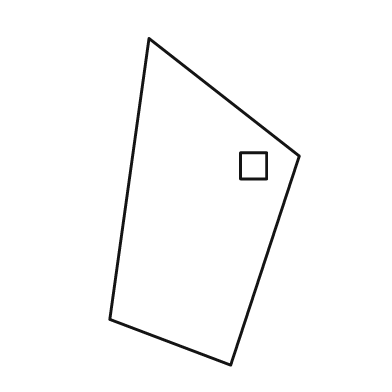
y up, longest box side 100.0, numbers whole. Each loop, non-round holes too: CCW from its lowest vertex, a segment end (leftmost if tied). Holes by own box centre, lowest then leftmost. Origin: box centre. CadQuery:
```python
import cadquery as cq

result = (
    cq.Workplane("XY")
    .moveTo(8.0, -50.0)
    .lineTo(29.0, 14.0)
    .lineTo(-17.0, 50.0)
    .lineTo(-29.0, -36.0)
    .close()
    .moveTo(11.0, 7.0)
    .lineTo(19.0, 7.0)
    .lineTo(19.0, 15.0)
    .lineTo(11.0, 15.0)
    .close()
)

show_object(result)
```